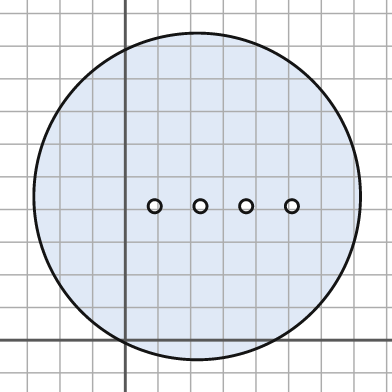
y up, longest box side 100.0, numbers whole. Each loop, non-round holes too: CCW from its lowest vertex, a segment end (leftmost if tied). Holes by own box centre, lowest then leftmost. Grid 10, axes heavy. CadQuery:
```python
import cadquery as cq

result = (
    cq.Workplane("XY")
    .moveTo(22.0, 44.0)
    .circle(50.0)
    .moveTo(9.0, 41.0)
    .circle(2.0)
    .moveTo(23.0, 41.0)
    .circle(2.0)
    .moveTo(37.0, 41.0)
    .circle(2.0)
    .moveTo(51.0, 41.0)
    .circle(2.0)
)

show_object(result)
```